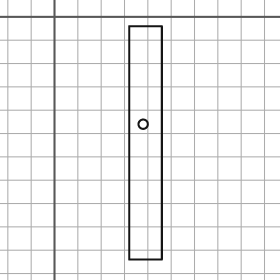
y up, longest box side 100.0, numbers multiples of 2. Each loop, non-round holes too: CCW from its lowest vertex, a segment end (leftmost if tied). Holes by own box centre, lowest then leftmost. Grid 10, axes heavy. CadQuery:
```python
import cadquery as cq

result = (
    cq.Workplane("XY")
    .moveTo(32.0, -104.0)
    .lineTo(46.0, -104.0)
    .lineTo(46.0, -4.0)
    .lineTo(32.0, -4.0)
    .close()
    .moveTo(38.0, -46.0)
    .circle(2.0)
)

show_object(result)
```